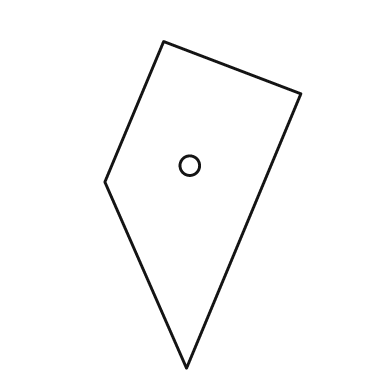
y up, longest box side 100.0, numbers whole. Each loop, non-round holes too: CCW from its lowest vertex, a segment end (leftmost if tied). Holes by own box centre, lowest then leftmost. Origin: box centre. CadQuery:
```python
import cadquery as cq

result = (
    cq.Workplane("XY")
    .moveTo(-5.0, -50.0)
    .lineTo(30.0, 34.0)
    .lineTo(-12.0, 50.0)
    .lineTo(-30.0, 7.0)
    .close()
    .moveTo(-4.0, 12.0)
    .circle(3.0)
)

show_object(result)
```